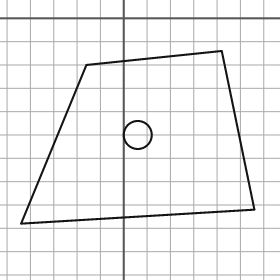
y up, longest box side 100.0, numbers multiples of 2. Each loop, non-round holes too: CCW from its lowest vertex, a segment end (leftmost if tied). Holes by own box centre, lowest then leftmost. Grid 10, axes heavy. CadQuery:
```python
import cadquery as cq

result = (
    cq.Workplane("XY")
    .moveTo(-44.0, -88.0)
    .lineTo(56.0, -82.0)
    .lineTo(42.0, -14.0)
    .lineTo(-16.0, -20.0)
    .close()
    .moveTo(6.0, -50.0)
    .circle(6.0)
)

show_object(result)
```